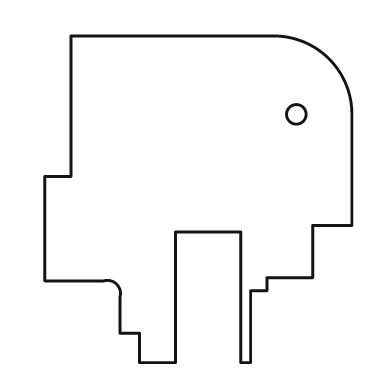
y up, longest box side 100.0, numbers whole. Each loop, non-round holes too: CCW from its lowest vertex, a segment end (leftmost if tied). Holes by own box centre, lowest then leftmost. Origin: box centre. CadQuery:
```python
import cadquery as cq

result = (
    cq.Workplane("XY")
    .moveTo(-18.0, -50.0)
    .lineTo(-7.0, -50.0)
    .lineTo(-7.0, -10.0)
    .lineTo(13.0, -10.0)
    .lineTo(13.0, -50.0)
    .lineTo(16.0, -50.0)
    .lineTo(16.0, -28.0)
    .lineTo(21.0, -28.0)
    .lineTo(21.0, -24.0)
    .lineTo(35.0, -24.0)
    .lineTo(35.0, -8.0)
    .lineTo(47.0, -8.0)
    .lineTo(47.0, 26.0)
    .threePointArc((40.0, 43.0), (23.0, 50.0))
    .lineTo(-39.0, 50.0)
    .lineTo(-39.0, 7.0)
    .lineTo(-47.0, 7.0)
    .lineTo(-47.0, -25.0)
    .lineTo(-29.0, -25.0)
    .threePointArc((-25.0, -26.0), (-24.0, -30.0))
    .lineTo(-24.0, -41.0)
    .lineTo(-18.0, -41.0)
    .close()
    .moveTo(30.0, 26.0)
    .circle(3.0)
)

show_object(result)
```